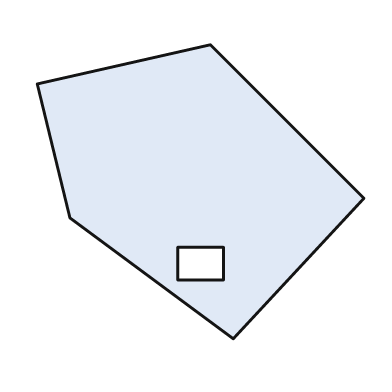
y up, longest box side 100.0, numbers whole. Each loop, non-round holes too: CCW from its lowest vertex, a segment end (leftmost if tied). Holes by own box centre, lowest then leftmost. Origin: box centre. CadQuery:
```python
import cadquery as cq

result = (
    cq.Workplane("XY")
    .moveTo(10.0, -45.0)
    .lineTo(50.0, -2.0)
    .lineTo(3.0, 45.0)
    .lineTo(-50.0, 33.0)
    .lineTo(-40.0, -8.0)
    .close()
    .moveTo(-7.0, -27.0)
    .lineTo(7.0, -27.0)
    .lineTo(7.0, -17.0)
    .lineTo(-7.0, -17.0)
    .close()
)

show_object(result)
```